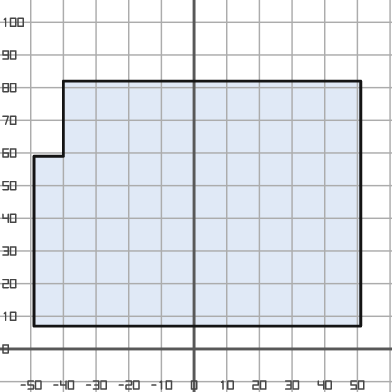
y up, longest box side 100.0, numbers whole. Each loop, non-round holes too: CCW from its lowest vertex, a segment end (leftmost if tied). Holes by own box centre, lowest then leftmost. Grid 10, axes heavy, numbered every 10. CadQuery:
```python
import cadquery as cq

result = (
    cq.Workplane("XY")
    .moveTo(-49.0, 7.0)
    .lineTo(51.0, 7.0)
    .lineTo(51.0, 82.0)
    .lineTo(-40.0, 82.0)
    .lineTo(-40.0, 59.0)
    .lineTo(-49.0, 59.0)
    .close()
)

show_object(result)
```